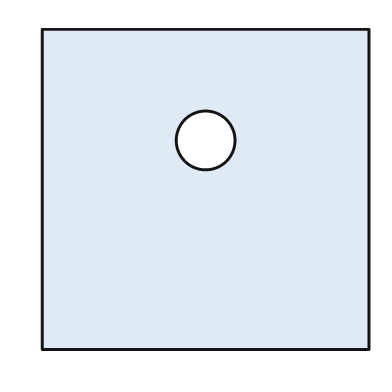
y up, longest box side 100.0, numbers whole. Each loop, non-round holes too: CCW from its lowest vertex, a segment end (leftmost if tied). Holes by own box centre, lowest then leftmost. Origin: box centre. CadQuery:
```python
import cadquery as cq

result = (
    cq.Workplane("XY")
    .moveTo(-50.0, -49.0)
    .lineTo(50.0, -49.0)
    .lineTo(50.0, 49.0)
    .lineTo(-50.0, 49.0)
    .close()
    .moveTo(0.0, 15.0)
    .circle(9.0)
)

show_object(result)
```